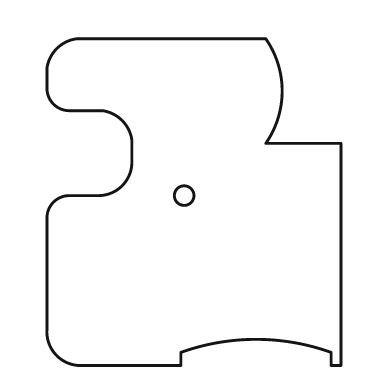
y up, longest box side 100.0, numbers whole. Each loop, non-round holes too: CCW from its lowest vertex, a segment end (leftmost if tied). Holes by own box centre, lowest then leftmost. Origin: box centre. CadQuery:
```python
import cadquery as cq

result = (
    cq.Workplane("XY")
    .moveTo(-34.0, -50.0)
    .lineTo(-4.0, -50.0)
    .lineTo(-4.0, -46.0)
    .threePointArc((19.0, -42.0), (42.0, -46.0))
    .lineTo(42.0, -50.0)
    .lineTo(45.0, -50.0)
    .lineTo(45.0, 18.0)
    .lineTo(22.0, 18.0)
    .threePointArc((27.0, 34.0), (22.0, 50.0))
    .lineTo(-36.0, 50.0)
    .threePointArc((-42.0, 47.0), (-45.0, 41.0))
    .lineTo(-45.0, 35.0)
    .threePointArc((-43.0, 30.0), (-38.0, 28.0))
    .lineTo(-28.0, 28.0)
    .threePointArc((-22.0, 25.0), (-19.0, 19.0))
    .lineTo(-19.0, 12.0)
    .threePointArc((-22.0, 5.0), (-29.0, 2.0))
    .lineTo(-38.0, 2.0)
    .threePointArc((-43.0, 0.0), (-45.0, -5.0))
    .lineTo(-45.0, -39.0)
    .threePointArc((-42.0, -47.0), (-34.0, -50.0))
    .close()
    .moveTo(-3.0, 2.0)
    .circle(3.0)
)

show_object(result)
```